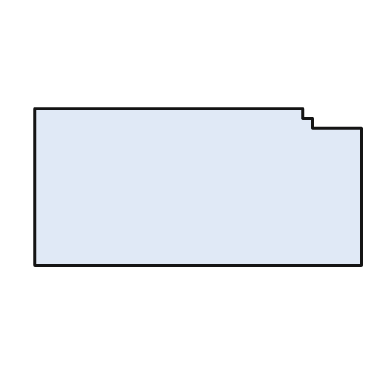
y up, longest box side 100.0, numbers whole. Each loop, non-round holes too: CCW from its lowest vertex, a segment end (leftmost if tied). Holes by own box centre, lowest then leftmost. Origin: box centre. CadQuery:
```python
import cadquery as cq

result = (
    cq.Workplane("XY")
    .moveTo(-50.0, -24.0)
    .lineTo(50.0, -24.0)
    .lineTo(50.0, 18.0)
    .lineTo(35.0, 18.0)
    .lineTo(35.0, 21.0)
    .lineTo(32.0, 21.0)
    .lineTo(32.0, 24.0)
    .lineTo(-50.0, 24.0)
    .close()
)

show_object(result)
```